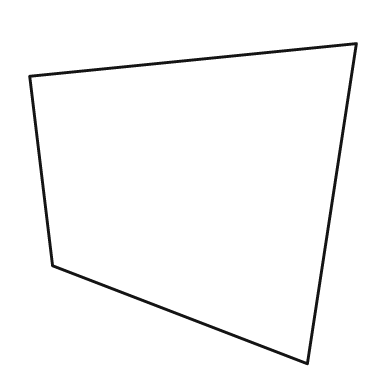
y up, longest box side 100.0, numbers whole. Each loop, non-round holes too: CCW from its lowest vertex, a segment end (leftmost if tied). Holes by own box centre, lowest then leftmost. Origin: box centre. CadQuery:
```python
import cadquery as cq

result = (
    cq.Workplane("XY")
    .moveTo(35.0, -49.0)
    .lineTo(50.0, 49.0)
    .lineTo(-50.0, 39.0)
    .lineTo(-43.0, -19.0)
    .close()
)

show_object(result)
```